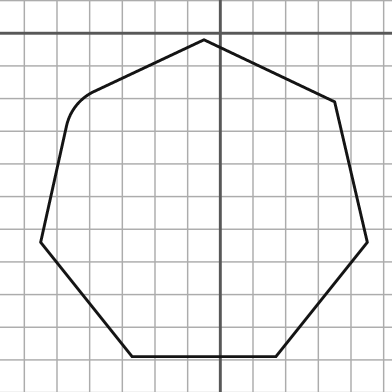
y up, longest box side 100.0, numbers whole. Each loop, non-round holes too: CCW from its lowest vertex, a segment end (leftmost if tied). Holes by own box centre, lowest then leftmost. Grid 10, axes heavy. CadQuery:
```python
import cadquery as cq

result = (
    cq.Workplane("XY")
    .moveTo(-27.0, -99.0)
    .lineTo(17.0, -99.0)
    .lineTo(45.0, -64.0)
    .lineTo(35.0, -21.0)
    .lineTo(-5.0, -2.0)
    .lineTo(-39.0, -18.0)
    .threePointArc((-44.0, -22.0), (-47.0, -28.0))
    .lineTo(-55.0, -64.0)
    .close()
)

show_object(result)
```